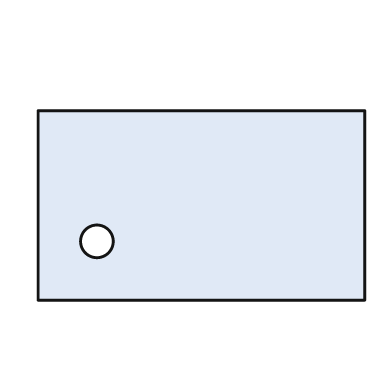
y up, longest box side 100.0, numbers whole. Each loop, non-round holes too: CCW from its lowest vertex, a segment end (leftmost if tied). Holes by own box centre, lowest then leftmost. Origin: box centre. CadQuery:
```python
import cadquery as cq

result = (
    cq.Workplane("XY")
    .moveTo(-50.0, -29.0)
    .lineTo(50.0, -29.0)
    .lineTo(50.0, 29.0)
    .lineTo(-50.0, 29.0)
    .close()
    .moveTo(-32.0, -11.0)
    .circle(5.0)
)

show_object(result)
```